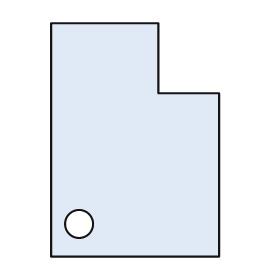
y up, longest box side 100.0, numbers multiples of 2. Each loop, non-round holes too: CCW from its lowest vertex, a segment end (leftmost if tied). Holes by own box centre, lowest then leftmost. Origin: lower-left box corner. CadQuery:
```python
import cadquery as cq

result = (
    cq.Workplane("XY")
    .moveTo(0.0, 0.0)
    .lineTo(72.0, 0.0)
    .lineTo(72.0, 70.0)
    .lineTo(46.0, 70.0)
    .lineTo(46.0, 100.0)
    .lineTo(0.0, 100.0)
    .close()
    .moveTo(12.0, 14.0)
    .circle(6.0)
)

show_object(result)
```